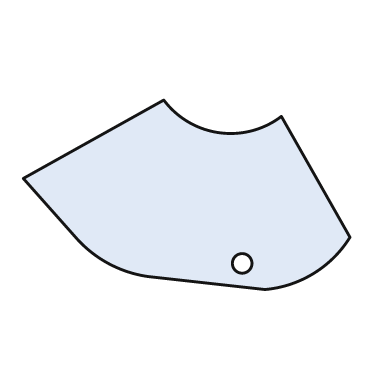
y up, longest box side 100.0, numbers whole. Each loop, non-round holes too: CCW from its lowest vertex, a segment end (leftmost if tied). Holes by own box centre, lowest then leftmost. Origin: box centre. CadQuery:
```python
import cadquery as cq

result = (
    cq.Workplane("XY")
    .moveTo(24.0, -29.0)
    .threePointArc((39.0, -24.0), (50.0, -13.0))
    .lineTo(29.0, 24.0)
    .threePointArc((10.0, 19.0), (-7.0, 29.0))
    .lineTo(-50.0, 5.0)
    .lineTo(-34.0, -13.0)
    .threePointArc((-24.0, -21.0), (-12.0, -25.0))
    .close()
    .moveTo(17.0, -21.0)
    .circle(3.0)
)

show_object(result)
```